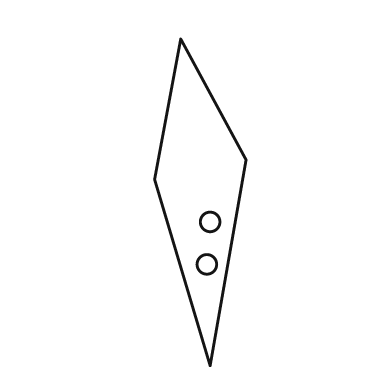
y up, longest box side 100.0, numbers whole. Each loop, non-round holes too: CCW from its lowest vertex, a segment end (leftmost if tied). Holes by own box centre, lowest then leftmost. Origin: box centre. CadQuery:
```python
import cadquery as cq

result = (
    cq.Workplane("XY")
    .moveTo(3.0, -50.0)
    .lineTo(14.0, 13.0)
    .lineTo(-6.0, 50.0)
    .lineTo(-14.0, 7.0)
    .close()
    .moveTo(2.0, -19.0)
    .circle(3.0)
    .moveTo(3.0, -6.0)
    .circle(3.0)
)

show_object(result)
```